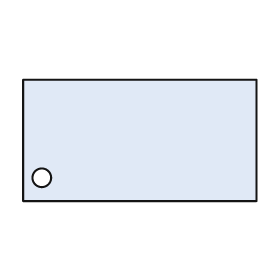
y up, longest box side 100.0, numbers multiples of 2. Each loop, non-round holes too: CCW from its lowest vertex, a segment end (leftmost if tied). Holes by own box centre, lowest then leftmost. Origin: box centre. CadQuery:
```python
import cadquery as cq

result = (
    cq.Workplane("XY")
    .moveTo(-50.0, -26.0)
    .lineTo(50.0, -26.0)
    .lineTo(50.0, 26.0)
    .lineTo(-50.0, 26.0)
    .close()
    .moveTo(-42.0, -16.0)
    .circle(4.0)
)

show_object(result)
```